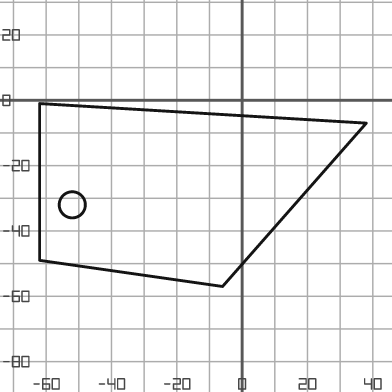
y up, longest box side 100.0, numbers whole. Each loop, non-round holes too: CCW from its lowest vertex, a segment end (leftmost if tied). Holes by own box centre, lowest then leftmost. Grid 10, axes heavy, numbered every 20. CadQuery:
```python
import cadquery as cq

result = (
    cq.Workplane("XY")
    .moveTo(-6.0, -57.0)
    .lineTo(38.0, -7.0)
    .lineTo(-62.0, -1.0)
    .lineTo(-62.0, -49.0)
    .close()
    .moveTo(-52.0, -32.0)
    .circle(4.0)
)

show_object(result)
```